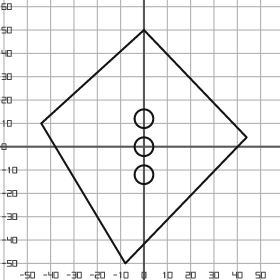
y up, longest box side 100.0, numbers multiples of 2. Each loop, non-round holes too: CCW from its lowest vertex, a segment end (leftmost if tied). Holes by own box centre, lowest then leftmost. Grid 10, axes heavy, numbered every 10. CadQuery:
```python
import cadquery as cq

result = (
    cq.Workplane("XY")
    .moveTo(-8.0, -50.0)
    .lineTo(44.0, 4.0)
    .lineTo(0.0, 50.0)
    .lineTo(-44.0, 10.0)
    .close()
    .moveTo(0.0, -12.0)
    .circle(4.0)
    .moveTo(0.0, 0.0)
    .circle(4.0)
    .moveTo(0.0, 12.0)
    .circle(4.0)
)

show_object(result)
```